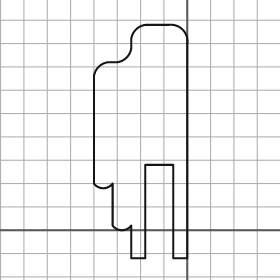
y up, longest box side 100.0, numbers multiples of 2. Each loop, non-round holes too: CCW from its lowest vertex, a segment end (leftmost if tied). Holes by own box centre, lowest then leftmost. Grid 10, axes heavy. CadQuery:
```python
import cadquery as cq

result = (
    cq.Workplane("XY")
    .moveTo(-24.0, -12.0)
    .lineTo(-18.0, -12.0)
    .lineTo(-18.0, 28.0)
    .lineTo(-6.0, 28.0)
    .lineTo(-6.0, -12.0)
    .lineTo(0.0, -12.0)
    .lineTo(0.0, 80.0)
    .threePointArc((-2.0, 86.0), (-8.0, 88.0))
    .lineTo(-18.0, 88.0)
    .threePointArc((-22.0, 86.0), (-24.0, 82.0))
    .lineTo(-24.0, 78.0)
    .threePointArc((-26.0, 74.0), (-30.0, 72.0))
    .lineTo(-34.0, 72.0)
    .threePointArc((-38.0, 70.0), (-40.0, 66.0))
    .lineTo(-40.0, 20.0)
    .threePointArc((-36.0, 18.0), (-32.0, 20.0))
    .lineTo(-32.0, 2.0)
    .threePointArc((-28.0, 0.0), (-24.0, 2.0))
    .close()
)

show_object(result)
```